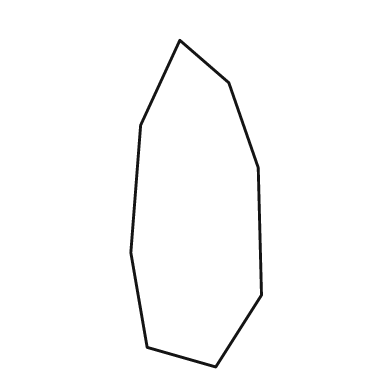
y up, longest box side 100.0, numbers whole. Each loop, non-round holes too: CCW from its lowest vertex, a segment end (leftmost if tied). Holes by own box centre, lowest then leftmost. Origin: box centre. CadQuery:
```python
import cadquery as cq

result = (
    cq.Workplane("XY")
    .moveTo(6.0, -50.0)
    .lineTo(20.0, -28.0)
    .lineTo(19.0, 11.0)
    .lineTo(10.0, 37.0)
    .lineTo(-5.0, 50.0)
    .lineTo(-17.0, 24.0)
    .lineTo(-20.0, -15.0)
    .lineTo(-15.0, -44.0)
    .close()
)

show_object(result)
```